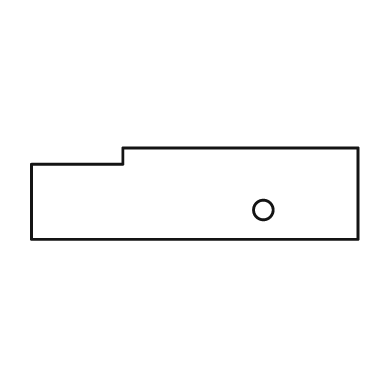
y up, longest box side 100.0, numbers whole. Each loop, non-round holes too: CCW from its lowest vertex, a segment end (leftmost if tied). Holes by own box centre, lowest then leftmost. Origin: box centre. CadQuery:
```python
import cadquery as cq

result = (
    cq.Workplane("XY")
    .moveTo(-50.0, -14.0)
    .lineTo(50.0, -14.0)
    .lineTo(50.0, 14.0)
    .lineTo(-22.0, 14.0)
    .lineTo(-22.0, 9.0)
    .lineTo(-50.0, 9.0)
    .close()
    .moveTo(21.0, -5.0)
    .circle(3.0)
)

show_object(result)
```